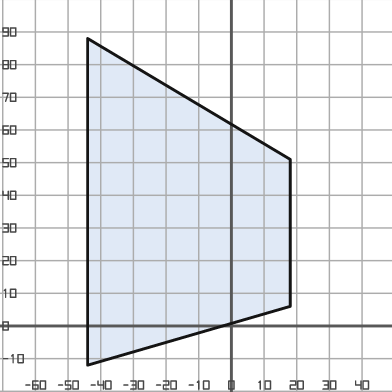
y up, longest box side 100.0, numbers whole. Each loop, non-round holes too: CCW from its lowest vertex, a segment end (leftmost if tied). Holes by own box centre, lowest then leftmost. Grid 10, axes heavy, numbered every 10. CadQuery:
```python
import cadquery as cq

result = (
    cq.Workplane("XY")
    .moveTo(-44.0, -12.0)
    .lineTo(18.0, 6.0)
    .lineTo(18.0, 51.0)
    .lineTo(-44.0, 88.0)
    .close()
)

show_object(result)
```